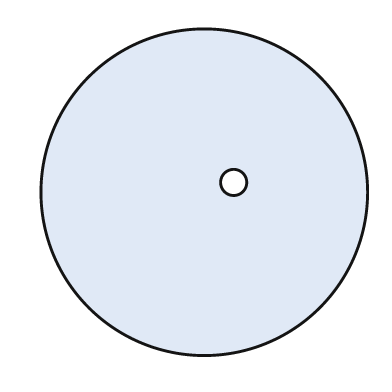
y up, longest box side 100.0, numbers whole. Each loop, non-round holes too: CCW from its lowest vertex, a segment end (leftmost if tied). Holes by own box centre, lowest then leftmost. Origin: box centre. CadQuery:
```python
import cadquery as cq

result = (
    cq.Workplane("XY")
    .moveTo(0.0, 0.0)
    .circle(50.0)
    .moveTo(9.0, 3.0)
    .circle(4.0)
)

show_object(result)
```